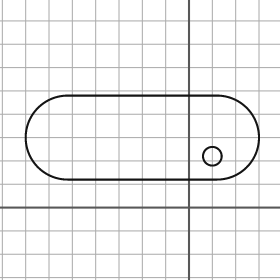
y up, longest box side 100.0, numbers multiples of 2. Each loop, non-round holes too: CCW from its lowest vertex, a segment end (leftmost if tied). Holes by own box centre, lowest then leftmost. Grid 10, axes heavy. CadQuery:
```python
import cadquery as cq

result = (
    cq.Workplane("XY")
    .moveTo(-52.0, 12.0)
    .lineTo(12.0, 12.0)
    .threePointArc((30.0, 30.0), (12.0, 48.0))
    .lineTo(-52.0, 48.0)
    .threePointArc((-70.0, 30.0), (-52.0, 12.0))
    .close()
    .moveTo(10.0, 22.0)
    .circle(4.0)
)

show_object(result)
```